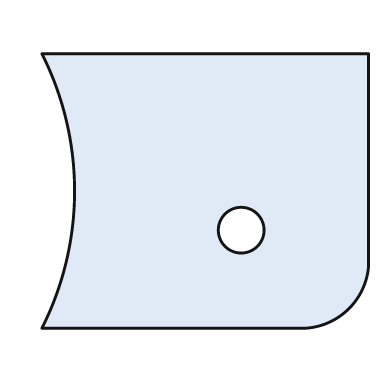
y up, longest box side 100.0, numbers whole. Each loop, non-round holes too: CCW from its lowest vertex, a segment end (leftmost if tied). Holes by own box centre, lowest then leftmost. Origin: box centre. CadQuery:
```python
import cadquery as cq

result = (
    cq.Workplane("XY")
    .moveTo(-50.0, -42.0)
    .lineTo(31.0, -42.0)
    .threePointArc((44.0, -36.0), (50.0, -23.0))
    .lineTo(50.0, 42.0)
    .lineTo(-50.0, 42.0)
    .threePointArc((-40.0, 0.0), (-50.0, -42.0))
    .close()
    .moveTo(11.0, -12.0)
    .circle(7.0)
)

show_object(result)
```